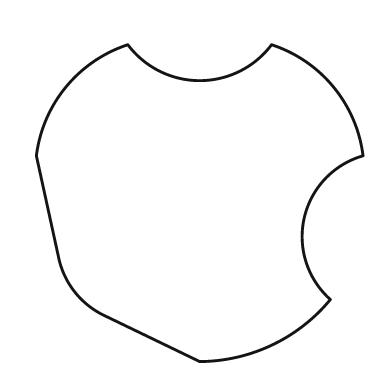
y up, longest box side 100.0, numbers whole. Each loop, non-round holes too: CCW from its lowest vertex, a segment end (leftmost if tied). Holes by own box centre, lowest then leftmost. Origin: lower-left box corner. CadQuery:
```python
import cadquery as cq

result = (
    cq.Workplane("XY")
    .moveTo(50.0, 0.0)
    .threePointArc((72.0, 5.0), (90.0, 19.0))
    .threePointArc((82.0, 44.0), (100.0, 63.0))
    .threePointArc((91.0, 84.0), (72.0, 97.0))
    .threePointArc((50.0, 86.0), (28.0, 97.0))
    .threePointArc((9.0, 84.0), (0.0, 63.0))
    .lineTo(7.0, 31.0)
    .threePointArc((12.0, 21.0), (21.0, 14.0))
    .close()
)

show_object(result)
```